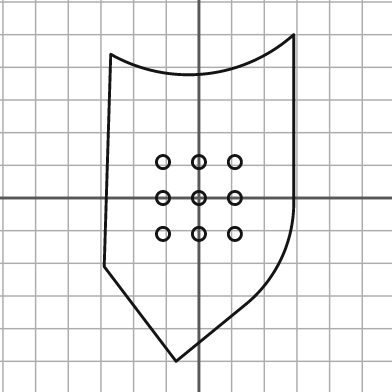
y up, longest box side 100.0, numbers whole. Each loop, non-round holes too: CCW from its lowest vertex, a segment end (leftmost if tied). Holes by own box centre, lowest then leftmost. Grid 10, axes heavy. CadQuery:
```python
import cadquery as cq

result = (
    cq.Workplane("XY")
    .moveTo(-7.0, -50.0)
    .lineTo(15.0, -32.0)
    .threePointArc((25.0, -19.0), (29.0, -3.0))
    .lineTo(29.0, 50.0)
    .threePointArc((2.0, 38.0), (-27.0, 44.0))
    .lineTo(-29.0, -21.0)
    .close()
    .moveTo(-11.0, -11.0)
    .circle(2.0)
    .moveTo(0.0, -11.0)
    .circle(2.0)
    .moveTo(11.0, -11.0)
    .circle(2.0)
    .moveTo(-11.0, 0.0)
    .circle(2.0)
    .moveTo(0.0, 0.0)
    .circle(2.0)
    .moveTo(11.0, 0.0)
    .circle(2.0)
    .moveTo(-11.0, 11.0)
    .circle(2.0)
    .moveTo(0.0, 11.0)
    .circle(2.0)
    .moveTo(11.0, 11.0)
    .circle(2.0)
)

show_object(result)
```